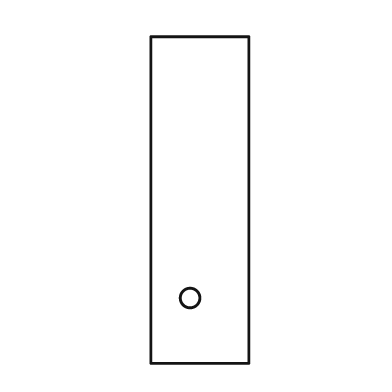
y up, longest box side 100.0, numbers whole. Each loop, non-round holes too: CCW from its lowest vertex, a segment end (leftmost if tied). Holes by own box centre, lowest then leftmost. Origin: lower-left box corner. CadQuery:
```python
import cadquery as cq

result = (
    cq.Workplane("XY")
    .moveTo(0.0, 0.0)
    .lineTo(30.0, 0.0)
    .lineTo(30.0, 100.0)
    .lineTo(0.0, 100.0)
    .close()
    .moveTo(12.0, 20.0)
    .circle(3.0)
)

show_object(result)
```